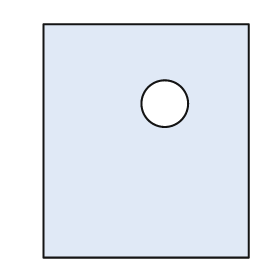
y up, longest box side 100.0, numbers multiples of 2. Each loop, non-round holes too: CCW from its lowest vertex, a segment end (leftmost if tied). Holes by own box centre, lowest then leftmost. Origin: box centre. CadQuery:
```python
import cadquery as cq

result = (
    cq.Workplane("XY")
    .moveTo(-44.0, -50.0)
    .lineTo(44.0, -50.0)
    .lineTo(44.0, 50.0)
    .lineTo(-44.0, 50.0)
    .close()
    .moveTo(8.0, 16.0)
    .circle(10.0)
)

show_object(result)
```